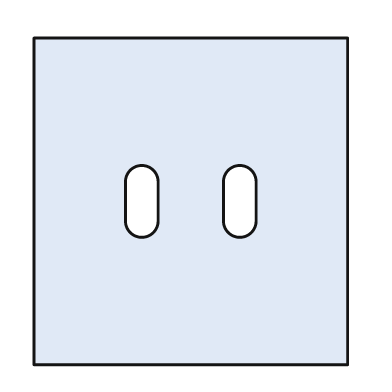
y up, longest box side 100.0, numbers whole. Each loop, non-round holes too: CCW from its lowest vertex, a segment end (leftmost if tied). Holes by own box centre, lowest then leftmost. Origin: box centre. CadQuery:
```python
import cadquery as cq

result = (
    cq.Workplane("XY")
    .moveTo(-48.0, -50.0)
    .lineTo(48.0, -50.0)
    .lineTo(48.0, 50.0)
    .lineTo(-48.0, 50.0)
    .close()
    .moveTo(-20.0, -6.0)
    .threePointArc((-15.0, -11.0), (-10.0, -6.0))
    .lineTo(-10.0, 6.0)
    .threePointArc((-15.0, 11.0), (-20.0, 6.0))
    .close()
    .moveTo(10.0, -6.0)
    .threePointArc((15.0, -11.0), (20.0, -6.0))
    .lineTo(20.0, 6.0)
    .threePointArc((15.0, 11.0), (10.0, 6.0))
    .close()
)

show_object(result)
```